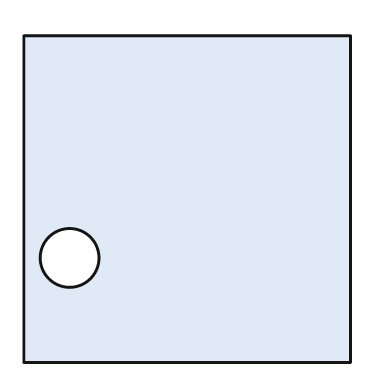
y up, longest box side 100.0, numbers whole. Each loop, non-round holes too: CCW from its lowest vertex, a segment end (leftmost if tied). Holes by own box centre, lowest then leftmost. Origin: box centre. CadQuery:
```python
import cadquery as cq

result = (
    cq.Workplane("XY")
    .moveTo(-50.0, -50.0)
    .lineTo(50.0, -50.0)
    .lineTo(50.0, 50.0)
    .lineTo(-50.0, 50.0)
    .close()
    .moveTo(-36.0, -18.0)
    .circle(9.0)
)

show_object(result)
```